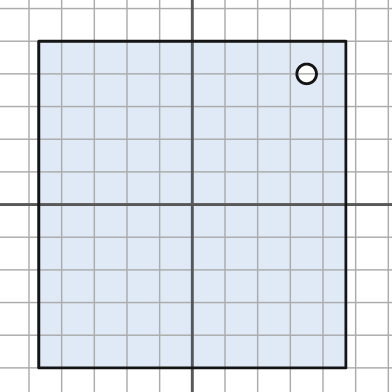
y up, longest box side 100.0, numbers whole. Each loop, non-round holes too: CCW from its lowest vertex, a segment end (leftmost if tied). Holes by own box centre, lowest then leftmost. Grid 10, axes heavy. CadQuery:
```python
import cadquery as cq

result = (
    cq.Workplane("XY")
    .moveTo(-47.0, -50.0)
    .lineTo(47.0, -50.0)
    .lineTo(47.0, 50.0)
    .lineTo(-47.0, 50.0)
    .close()
    .moveTo(35.0, 40.0)
    .circle(3.0)
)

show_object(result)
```